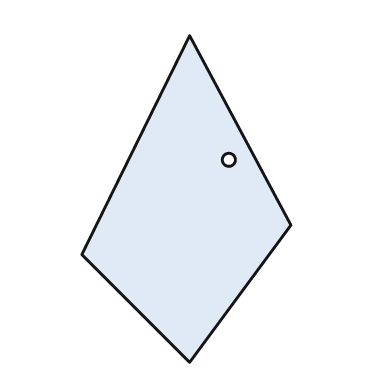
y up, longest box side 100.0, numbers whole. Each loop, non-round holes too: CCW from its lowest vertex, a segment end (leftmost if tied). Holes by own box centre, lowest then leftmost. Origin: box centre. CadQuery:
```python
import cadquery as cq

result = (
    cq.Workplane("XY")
    .moveTo(1.0, -50.0)
    .lineTo(32.0, -8.0)
    .lineTo(1.0, 50.0)
    .lineTo(-32.0, -17.0)
    .close()
    .moveTo(13.0, 12.0)
    .circle(2.0)
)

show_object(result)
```